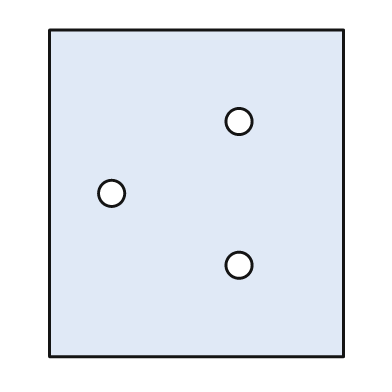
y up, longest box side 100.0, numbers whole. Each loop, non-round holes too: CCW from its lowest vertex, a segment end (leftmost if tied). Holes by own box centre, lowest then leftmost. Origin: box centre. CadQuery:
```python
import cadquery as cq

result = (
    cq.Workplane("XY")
    .moveTo(-45.0, -50.0)
    .lineTo(45.0, -50.0)
    .lineTo(45.0, 50.0)
    .lineTo(-45.0, 50.0)
    .close()
    .moveTo(13.0, -22.0)
    .circle(4.0)
    .moveTo(-26.0, 0.0)
    .circle(4.0)
    .moveTo(13.0, 22.0)
    .circle(4.0)
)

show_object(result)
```